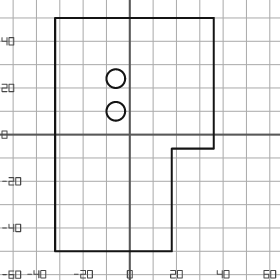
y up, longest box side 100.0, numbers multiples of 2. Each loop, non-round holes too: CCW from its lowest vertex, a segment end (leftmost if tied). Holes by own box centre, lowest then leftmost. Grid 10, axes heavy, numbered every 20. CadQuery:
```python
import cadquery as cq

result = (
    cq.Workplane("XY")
    .moveTo(-32.0, -50.0)
    .lineTo(18.0, -50.0)
    .lineTo(18.0, -6.0)
    .lineTo(36.0, -6.0)
    .lineTo(36.0, 50.0)
    .lineTo(-32.0, 50.0)
    .close()
    .moveTo(-6.0, 10.0)
    .circle(4.0)
    .moveTo(-6.0, 24.0)
    .circle(4.0)
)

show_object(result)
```